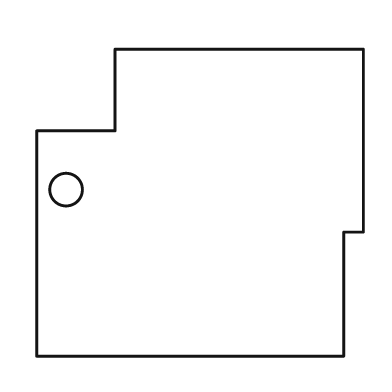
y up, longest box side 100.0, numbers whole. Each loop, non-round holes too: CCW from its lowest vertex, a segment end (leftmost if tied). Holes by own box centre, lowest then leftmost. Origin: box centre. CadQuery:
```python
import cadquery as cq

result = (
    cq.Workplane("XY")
    .moveTo(-50.0, -47.0)
    .lineTo(44.0, -47.0)
    .lineTo(44.0, -9.0)
    .lineTo(50.0, -9.0)
    .lineTo(50.0, 47.0)
    .lineTo(-26.0, 47.0)
    .lineTo(-26.0, 22.0)
    .lineTo(-50.0, 22.0)
    .close()
    .moveTo(-41.0, 4.0)
    .circle(5.0)
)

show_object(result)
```